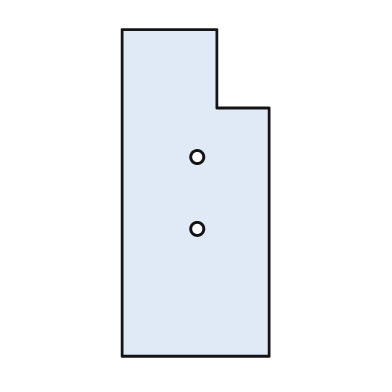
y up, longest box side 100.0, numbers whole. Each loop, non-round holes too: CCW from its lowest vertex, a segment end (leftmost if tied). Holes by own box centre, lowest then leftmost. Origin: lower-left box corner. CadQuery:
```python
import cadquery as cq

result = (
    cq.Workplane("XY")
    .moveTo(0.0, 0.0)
    .lineTo(45.0, 0.0)
    .lineTo(45.0, 76.0)
    .lineTo(29.0, 76.0)
    .lineTo(29.0, 100.0)
    .lineTo(0.0, 100.0)
    .close()
    .moveTo(23.0, 39.0)
    .circle(2.0)
    .moveTo(23.0, 61.0)
    .circle(2.0)
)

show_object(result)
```